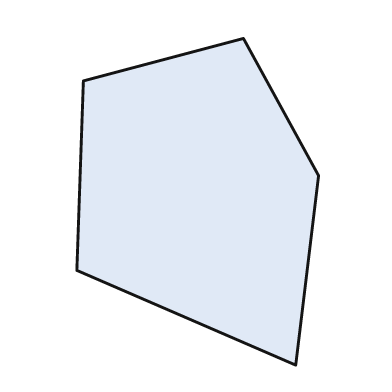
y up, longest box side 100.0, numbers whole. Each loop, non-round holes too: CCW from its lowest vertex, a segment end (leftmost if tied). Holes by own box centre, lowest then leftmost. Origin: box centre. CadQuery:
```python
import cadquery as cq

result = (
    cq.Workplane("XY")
    .moveTo(30.0, -50.0)
    .lineTo(37.0, 8.0)
    .lineTo(14.0, 50.0)
    .lineTo(-35.0, 37.0)
    .lineTo(-37.0, -21.0)
    .close()
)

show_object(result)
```